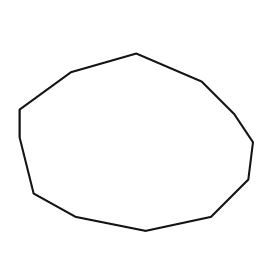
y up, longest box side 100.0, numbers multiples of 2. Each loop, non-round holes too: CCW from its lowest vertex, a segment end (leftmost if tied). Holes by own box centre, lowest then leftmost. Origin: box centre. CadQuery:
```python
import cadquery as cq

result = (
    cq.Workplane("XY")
    .moveTo(4.0, -38.0)
    .lineTo(32.0, -32.0)
    .lineTo(48.0, -16.0)
    .lineTo(50.0, 0.0)
    .lineTo(42.0, 12.0)
    .lineTo(28.0, 26.0)
    .lineTo(0.0, 38.0)
    .lineTo(-28.0, 30.0)
    .lineTo(-50.0, 14.0)
    .lineTo(-50.0, 2.0)
    .lineTo(-44.0, -22.0)
    .lineTo(-26.0, -32.0)
    .close()
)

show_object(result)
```